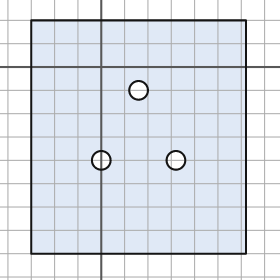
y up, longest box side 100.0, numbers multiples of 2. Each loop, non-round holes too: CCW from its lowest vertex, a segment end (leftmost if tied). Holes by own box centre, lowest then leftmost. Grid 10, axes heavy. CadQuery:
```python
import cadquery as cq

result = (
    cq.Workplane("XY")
    .moveTo(-30.0, -80.0)
    .lineTo(62.0, -80.0)
    .lineTo(62.0, 20.0)
    .lineTo(-30.0, 20.0)
    .close()
    .moveTo(0.0, -40.0)
    .circle(4.0)
    .moveTo(32.0, -40.0)
    .circle(4.0)
    .moveTo(16.0, -10.0)
    .circle(4.0)
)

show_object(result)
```